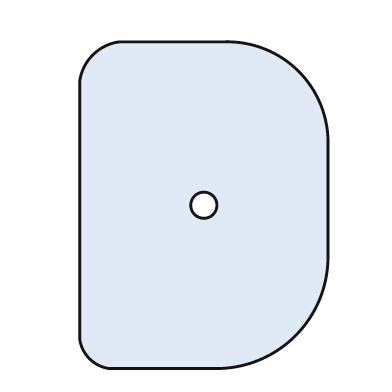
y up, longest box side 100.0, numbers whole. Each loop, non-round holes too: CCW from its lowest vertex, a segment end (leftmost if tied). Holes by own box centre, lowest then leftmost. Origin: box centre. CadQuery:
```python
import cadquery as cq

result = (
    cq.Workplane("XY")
    .moveTo(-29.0, -50.0)
    .lineTo(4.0, -50.0)
    .threePointArc((28.0, -40.0), (38.0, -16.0))
    .lineTo(38.0, 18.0)
    .threePointArc((29.0, 41.0), (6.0, 50.0))
    .lineTo(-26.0, 50.0)
    .threePointArc((-34.0, 46.0), (-38.0, 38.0))
    .lineTo(-38.0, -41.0)
    .threePointArc((-35.0, -47.0), (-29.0, -50.0))
    .close()
    .moveTo(0.0, 0.0)
    .circle(4.0)
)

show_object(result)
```